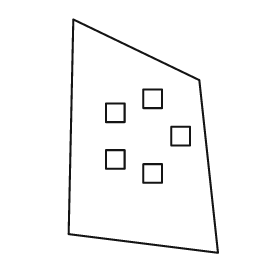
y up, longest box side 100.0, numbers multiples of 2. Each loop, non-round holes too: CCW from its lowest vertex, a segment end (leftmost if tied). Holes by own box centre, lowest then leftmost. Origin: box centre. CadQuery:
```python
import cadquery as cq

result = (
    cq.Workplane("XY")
    .moveTo(32.0, -50.0)
    .lineTo(24.0, 24.0)
    .lineTo(-30.0, 50.0)
    .lineTo(-32.0, -42.0)
    .close()
    .moveTo(0.0, -20.0)
    .lineTo(8.0, -20.0)
    .lineTo(8.0, -12.0)
    .lineTo(0.0, -12.0)
    .close()
    .moveTo(-16.0, -14.0)
    .lineTo(-8.0, -14.0)
    .lineTo(-8.0, -6.0)
    .lineTo(-16.0, -6.0)
    .close()
    .moveTo(12.0, -4.0)
    .lineTo(20.0, -4.0)
    .lineTo(20.0, 4.0)
    .lineTo(12.0, 4.0)
    .close()
    .moveTo(-16.0, 6.0)
    .lineTo(-8.0, 6.0)
    .lineTo(-8.0, 14.0)
    .lineTo(-16.0, 14.0)
    .close()
    .moveTo(0.0, 12.0)
    .lineTo(8.0, 12.0)
    .lineTo(8.0, 20.0)
    .lineTo(0.0, 20.0)
    .close()
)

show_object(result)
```